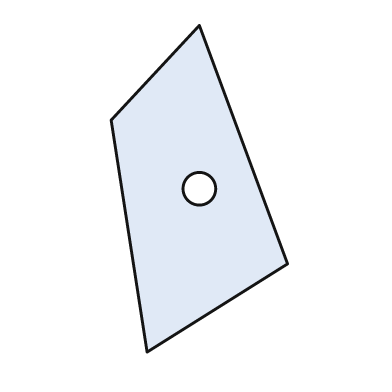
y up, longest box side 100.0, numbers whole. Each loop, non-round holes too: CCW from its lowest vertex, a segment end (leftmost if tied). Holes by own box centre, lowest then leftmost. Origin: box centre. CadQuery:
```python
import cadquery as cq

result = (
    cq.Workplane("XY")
    .moveTo(-16.0, -50.0)
    .lineTo(27.0, -23.0)
    .lineTo(0.0, 50.0)
    .lineTo(-27.0, 21.0)
    .close()
    .moveTo(0.0, 0.0)
    .circle(5.0)
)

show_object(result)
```